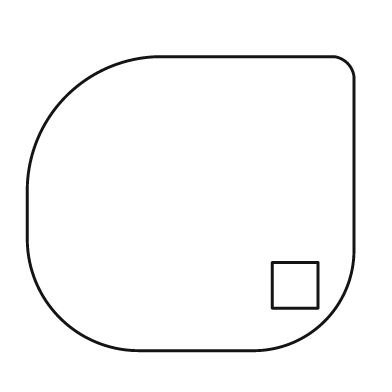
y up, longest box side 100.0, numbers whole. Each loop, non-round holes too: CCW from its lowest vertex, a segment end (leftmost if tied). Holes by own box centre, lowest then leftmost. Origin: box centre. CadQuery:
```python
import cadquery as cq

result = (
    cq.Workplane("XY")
    .moveTo(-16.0, -45.0)
    .lineTo(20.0, -45.0)
    .threePointArc((41.0, -36.0), (50.0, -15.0))
    .lineTo(50.0, 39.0)
    .threePointArc((48.0, 43.0), (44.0, 45.0))
    .lineTo(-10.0, 45.0)
    .threePointArc((-38.0, 33.0), (-50.0, 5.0))
    .lineTo(-50.0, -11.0)
    .threePointArc((-40.0, -35.0), (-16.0, -45.0))
    .close()
    .moveTo(25.0, -32.0)
    .lineTo(39.0, -32.0)
    .lineTo(39.0, -18.0)
    .lineTo(25.0, -18.0)
    .close()
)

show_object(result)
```